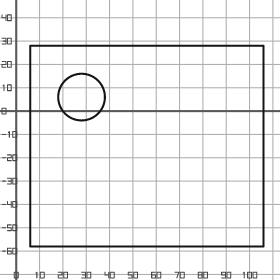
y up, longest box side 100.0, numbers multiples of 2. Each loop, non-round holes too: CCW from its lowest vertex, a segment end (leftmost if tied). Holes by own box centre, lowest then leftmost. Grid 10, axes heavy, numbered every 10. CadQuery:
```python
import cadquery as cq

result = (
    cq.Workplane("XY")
    .moveTo(6.0, -58.0)
    .lineTo(106.0, -58.0)
    .lineTo(106.0, 28.0)
    .lineTo(6.0, 28.0)
    .close()
    .moveTo(28.0, 6.0)
    .circle(10.0)
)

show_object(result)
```